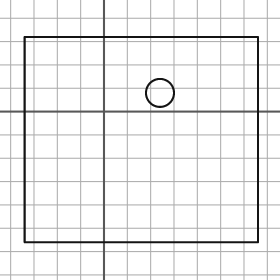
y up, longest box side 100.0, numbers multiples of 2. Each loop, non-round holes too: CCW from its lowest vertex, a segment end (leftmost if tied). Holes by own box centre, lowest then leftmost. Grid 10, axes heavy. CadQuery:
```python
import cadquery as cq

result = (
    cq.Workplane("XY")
    .moveTo(-34.0, -56.0)
    .lineTo(66.0, -56.0)
    .lineTo(66.0, 32.0)
    .lineTo(-34.0, 32.0)
    .close()
    .moveTo(24.0, 8.0)
    .circle(6.0)
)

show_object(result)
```